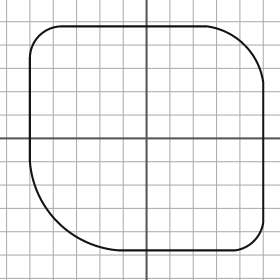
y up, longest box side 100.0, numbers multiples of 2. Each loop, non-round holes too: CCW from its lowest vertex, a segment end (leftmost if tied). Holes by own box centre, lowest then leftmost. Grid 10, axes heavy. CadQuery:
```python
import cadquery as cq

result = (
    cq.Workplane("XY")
    .moveTo(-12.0, -48.0)
    .lineTo(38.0, -48.0)
    .threePointArc((46.0, -44.0), (50.0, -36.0))
    .lineTo(50.0, 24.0)
    .threePointArc((42.0, 40.0), (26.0, 48.0))
    .lineTo(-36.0, 48.0)
    .threePointArc((-46.0, 44.0), (-50.0, 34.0))
    .lineTo(-50.0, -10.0)
    .threePointArc((-38.0, -36.0), (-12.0, -48.0))
    .close()
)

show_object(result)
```